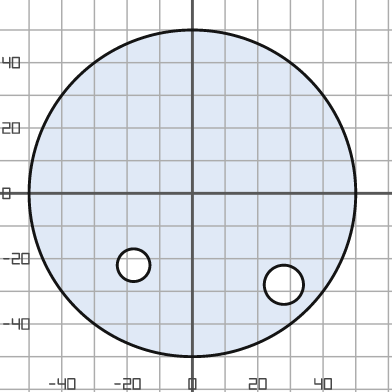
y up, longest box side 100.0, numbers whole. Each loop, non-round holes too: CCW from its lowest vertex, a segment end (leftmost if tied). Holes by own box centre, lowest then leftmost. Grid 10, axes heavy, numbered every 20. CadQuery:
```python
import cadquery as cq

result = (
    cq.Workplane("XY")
    .moveTo(0.0, 0.0)
    .circle(50.0)
    .moveTo(28.0, -28.0)
    .circle(6.0)
    .moveTo(-18.0, -22.0)
    .circle(5.0)
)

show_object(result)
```